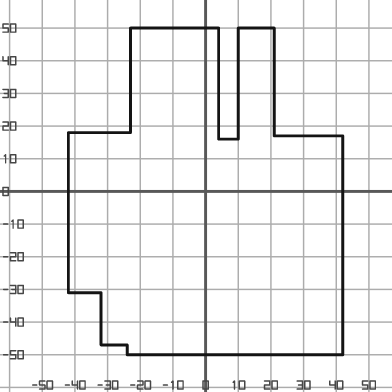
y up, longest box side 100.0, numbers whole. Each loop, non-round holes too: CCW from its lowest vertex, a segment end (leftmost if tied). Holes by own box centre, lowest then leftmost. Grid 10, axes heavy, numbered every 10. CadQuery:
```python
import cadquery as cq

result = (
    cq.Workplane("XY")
    .moveTo(-24.0, -50.0)
    .lineTo(42.0, -50.0)
    .lineTo(42.0, 17.0)
    .lineTo(21.0, 17.0)
    .lineTo(21.0, 50.0)
    .lineTo(10.0, 50.0)
    .lineTo(10.0, 16.0)
    .lineTo(4.0, 16.0)
    .lineTo(4.0, 50.0)
    .lineTo(-23.0, 50.0)
    .lineTo(-23.0, 18.0)
    .lineTo(-42.0, 18.0)
    .lineTo(-42.0, -31.0)
    .lineTo(-32.0, -31.0)
    .lineTo(-32.0, -47.0)
    .lineTo(-24.0, -47.0)
    .close()
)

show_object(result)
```